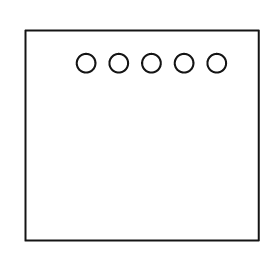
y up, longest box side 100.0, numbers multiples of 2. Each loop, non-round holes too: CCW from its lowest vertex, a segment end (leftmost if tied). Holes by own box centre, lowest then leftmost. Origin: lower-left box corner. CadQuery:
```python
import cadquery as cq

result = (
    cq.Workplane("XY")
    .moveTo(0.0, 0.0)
    .lineTo(100.0, 0.0)
    .lineTo(100.0, 90.0)
    .lineTo(0.0, 90.0)
    .close()
    .moveTo(26.0, 76.0)
    .circle(4.0)
    .moveTo(40.0, 76.0)
    .circle(4.0)
    .moveTo(54.0, 76.0)
    .circle(4.0)
    .moveTo(68.0, 76.0)
    .circle(4.0)
    .moveTo(82.0, 76.0)
    .circle(4.0)
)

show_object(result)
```